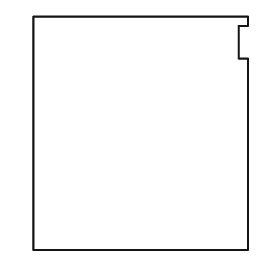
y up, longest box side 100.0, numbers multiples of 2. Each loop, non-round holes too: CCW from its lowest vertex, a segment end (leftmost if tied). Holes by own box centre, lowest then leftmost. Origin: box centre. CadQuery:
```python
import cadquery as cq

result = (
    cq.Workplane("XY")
    .moveTo(-46.0, -50.0)
    .lineTo(46.0, -50.0)
    .lineTo(46.0, 32.0)
    .lineTo(42.0, 32.0)
    .lineTo(42.0, 46.0)
    .lineTo(46.0, 46.0)
    .lineTo(46.0, 50.0)
    .lineTo(-46.0, 50.0)
    .close()
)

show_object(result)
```